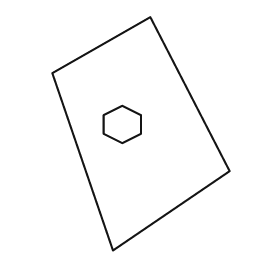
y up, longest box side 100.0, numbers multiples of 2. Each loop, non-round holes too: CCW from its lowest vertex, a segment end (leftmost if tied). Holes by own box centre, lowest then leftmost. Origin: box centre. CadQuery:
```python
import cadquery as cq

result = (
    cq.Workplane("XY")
    .moveTo(-12.0, -50.0)
    .lineTo(38.0, -16.0)
    .lineTo(4.0, 50.0)
    .lineTo(-38.0, 26.0)
    .close()
    .moveTo(-8.0, -4.0)
    .lineTo(0.0, 0.0)
    .lineTo(0.0, 8.0)
    .lineTo(-8.0, 12.0)
    .lineTo(-16.0, 8.0)
    .lineTo(-16.0, 0.0)
    .close()
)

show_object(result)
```